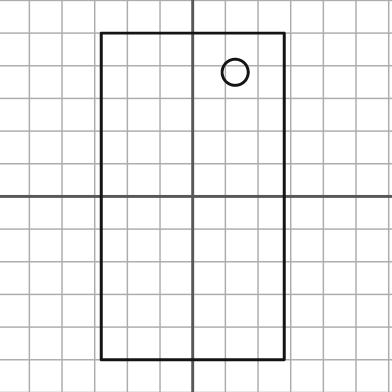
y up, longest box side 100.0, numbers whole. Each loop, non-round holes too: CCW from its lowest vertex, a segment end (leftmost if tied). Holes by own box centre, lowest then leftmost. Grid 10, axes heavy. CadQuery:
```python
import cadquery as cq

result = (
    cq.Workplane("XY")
    .moveTo(-28.0, -50.0)
    .lineTo(28.0, -50.0)
    .lineTo(28.0, 50.0)
    .lineTo(-28.0, 50.0)
    .close()
    .moveTo(13.0, 38.0)
    .circle(4.0)
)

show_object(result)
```